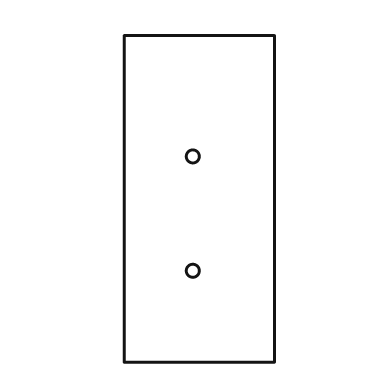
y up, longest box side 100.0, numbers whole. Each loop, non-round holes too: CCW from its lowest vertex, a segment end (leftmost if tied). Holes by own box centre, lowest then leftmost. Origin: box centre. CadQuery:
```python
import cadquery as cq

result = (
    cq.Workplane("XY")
    .moveTo(-23.0, -50.0)
    .lineTo(23.0, -50.0)
    .lineTo(23.0, 50.0)
    .lineTo(-23.0, 50.0)
    .close()
    .moveTo(-2.0, -22.0)
    .circle(2.0)
    .moveTo(-2.0, 13.0)
    .circle(2.0)
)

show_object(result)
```